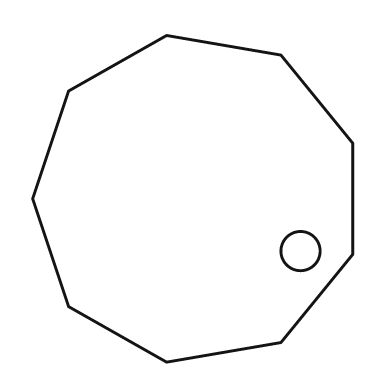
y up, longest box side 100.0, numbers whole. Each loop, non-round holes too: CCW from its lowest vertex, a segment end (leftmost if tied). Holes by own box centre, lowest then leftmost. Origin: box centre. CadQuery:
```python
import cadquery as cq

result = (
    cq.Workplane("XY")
    .moveTo(-8.0, -50.0)
    .lineTo(27.0, -44.0)
    .lineTo(49.0, -17.0)
    .lineTo(49.0, 17.0)
    .lineTo(27.0, 44.0)
    .lineTo(-8.0, 50.0)
    .lineTo(-38.0, 33.0)
    .lineTo(-49.0, 0.0)
    .lineTo(-38.0, -33.0)
    .close()
    .moveTo(33.0, -16.0)
    .circle(6.0)
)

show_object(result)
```